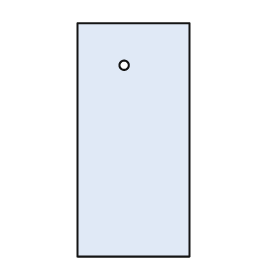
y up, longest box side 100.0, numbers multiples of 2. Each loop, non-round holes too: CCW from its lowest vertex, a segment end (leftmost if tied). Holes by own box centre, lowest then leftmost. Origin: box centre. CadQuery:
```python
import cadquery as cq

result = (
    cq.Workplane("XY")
    .moveTo(-24.0, -50.0)
    .lineTo(24.0, -50.0)
    .lineTo(24.0, 50.0)
    .lineTo(-24.0, 50.0)
    .close()
    .moveTo(-4.0, 32.0)
    .circle(2.0)
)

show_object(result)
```